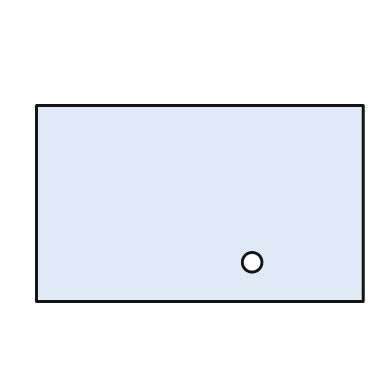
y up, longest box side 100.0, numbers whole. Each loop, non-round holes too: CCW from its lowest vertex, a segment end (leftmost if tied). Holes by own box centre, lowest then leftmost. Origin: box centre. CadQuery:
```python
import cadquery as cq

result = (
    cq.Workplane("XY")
    .moveTo(-50.0, -30.0)
    .lineTo(50.0, -30.0)
    .lineTo(50.0, 30.0)
    .lineTo(-50.0, 30.0)
    .close()
    .moveTo(16.0, -18.0)
    .circle(3.0)
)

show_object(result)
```